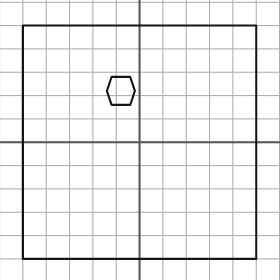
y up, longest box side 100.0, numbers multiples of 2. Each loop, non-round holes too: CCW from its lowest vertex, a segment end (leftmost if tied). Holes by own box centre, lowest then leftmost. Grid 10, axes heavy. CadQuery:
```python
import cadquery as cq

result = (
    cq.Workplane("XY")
    .moveTo(-50.0, -50.0)
    .lineTo(50.0, -50.0)
    .lineTo(50.0, 50.0)
    .lineTo(-50.0, 50.0)
    .close()
    .moveTo(-12.0, 16.0)
    .lineTo(-4.0, 16.0)
    .lineTo(-2.0, 22.0)
    .lineTo(-4.0, 28.0)
    .lineTo(-12.0, 28.0)
    .lineTo(-14.0, 22.0)
    .close()
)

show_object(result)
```